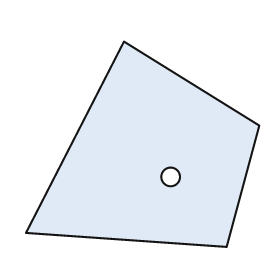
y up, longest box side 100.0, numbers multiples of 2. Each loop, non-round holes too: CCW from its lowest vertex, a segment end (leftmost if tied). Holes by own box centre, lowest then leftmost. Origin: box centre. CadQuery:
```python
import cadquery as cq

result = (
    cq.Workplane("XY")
    .moveTo(36.0, -44.0)
    .lineTo(50.0, 8.0)
    .lineTo(-8.0, 44.0)
    .lineTo(-50.0, -38.0)
    .close()
    .moveTo(12.0, -14.0)
    .circle(4.0)
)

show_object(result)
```